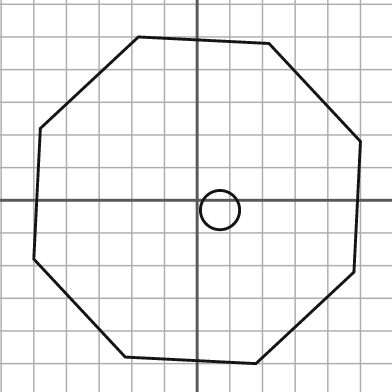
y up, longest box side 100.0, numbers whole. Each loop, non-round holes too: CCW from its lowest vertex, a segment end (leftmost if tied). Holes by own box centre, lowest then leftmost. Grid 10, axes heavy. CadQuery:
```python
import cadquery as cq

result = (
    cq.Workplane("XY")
    .moveTo(18.0, -50.0)
    .lineTo(48.0, -22.0)
    .lineTo(50.0, 18.0)
    .lineTo(22.0, 48.0)
    .lineTo(-18.0, 50.0)
    .lineTo(-48.0, 22.0)
    .lineTo(-50.0, -18.0)
    .lineTo(-22.0, -48.0)
    .close()
    .moveTo(7.0, -3.0)
    .circle(6.0)
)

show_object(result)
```